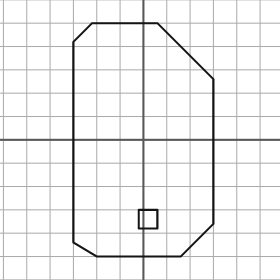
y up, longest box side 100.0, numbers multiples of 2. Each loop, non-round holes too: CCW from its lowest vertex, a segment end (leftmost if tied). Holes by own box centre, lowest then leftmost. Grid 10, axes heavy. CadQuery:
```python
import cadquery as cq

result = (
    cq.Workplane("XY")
    .moveTo(-20.0, -50.0)
    .lineTo(16.0, -50.0)
    .lineTo(30.0, -36.0)
    .lineTo(30.0, 26.0)
    .lineTo(6.0, 50.0)
    .lineTo(-22.0, 50.0)
    .lineTo(-30.0, 42.0)
    .lineTo(-30.0, -44.0)
    .close()
    .moveTo(-2.0, -38.0)
    .lineTo(6.0, -38.0)
    .lineTo(6.0, -30.0)
    .lineTo(-2.0, -30.0)
    .close()
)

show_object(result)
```